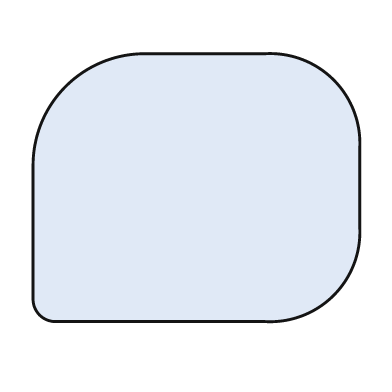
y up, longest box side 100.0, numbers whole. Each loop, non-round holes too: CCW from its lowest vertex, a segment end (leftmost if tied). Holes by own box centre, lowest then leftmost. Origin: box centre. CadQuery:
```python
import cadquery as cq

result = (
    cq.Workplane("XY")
    .moveTo(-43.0, -41.0)
    .lineTo(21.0, -41.0)
    .threePointArc((42.0, -33.0), (50.0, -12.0))
    .lineTo(50.0, 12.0)
    .threePointArc((42.0, 33.0), (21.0, 41.0))
    .lineTo(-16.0, 41.0)
    .threePointArc((-40.0, 31.0), (-50.0, 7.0))
    .lineTo(-50.0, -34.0)
    .threePointArc((-48.0, -39.0), (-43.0, -41.0))
    .close()
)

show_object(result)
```